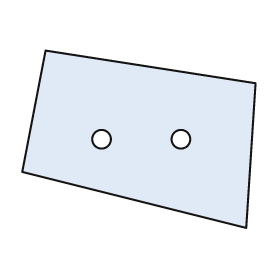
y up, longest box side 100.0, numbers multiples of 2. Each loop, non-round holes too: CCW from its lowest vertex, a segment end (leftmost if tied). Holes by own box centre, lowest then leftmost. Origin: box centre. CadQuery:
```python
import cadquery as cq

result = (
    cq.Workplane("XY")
    .moveTo(46.0, -38.0)
    .lineTo(50.0, 24.0)
    .lineTo(-40.0, 38.0)
    .lineTo(-50.0, -14.0)
    .close()
    .moveTo(-16.0, 0.0)
    .circle(4.0)
    .moveTo(18.0, 0.0)
    .circle(4.0)
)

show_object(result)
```